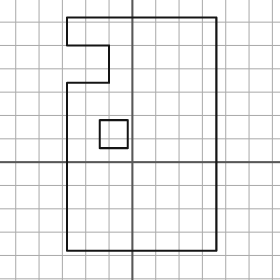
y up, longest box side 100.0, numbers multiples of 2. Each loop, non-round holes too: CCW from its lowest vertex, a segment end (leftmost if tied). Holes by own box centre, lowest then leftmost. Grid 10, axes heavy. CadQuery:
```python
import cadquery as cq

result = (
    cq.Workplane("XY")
    .moveTo(-28.0, -38.0)
    .lineTo(36.0, -38.0)
    .lineTo(36.0, 62.0)
    .lineTo(-28.0, 62.0)
    .lineTo(-28.0, 50.0)
    .lineTo(-10.0, 50.0)
    .lineTo(-10.0, 34.0)
    .lineTo(-28.0, 34.0)
    .close()
    .moveTo(-14.0, 6.0)
    .lineTo(-2.0, 6.0)
    .lineTo(-2.0, 18.0)
    .lineTo(-14.0, 18.0)
    .close()
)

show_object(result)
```